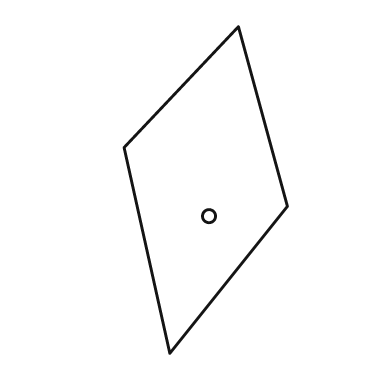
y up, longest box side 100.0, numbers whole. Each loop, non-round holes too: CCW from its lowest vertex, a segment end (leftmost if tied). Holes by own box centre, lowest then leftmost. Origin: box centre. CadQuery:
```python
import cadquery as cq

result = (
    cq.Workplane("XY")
    .moveTo(-11.0, -50.0)
    .lineTo(25.0, -5.0)
    .lineTo(10.0, 50.0)
    .lineTo(-25.0, 13.0)
    .close()
    .moveTo(1.0, -8.0)
    .circle(2.0)
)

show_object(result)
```